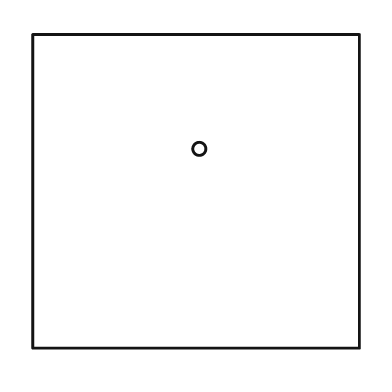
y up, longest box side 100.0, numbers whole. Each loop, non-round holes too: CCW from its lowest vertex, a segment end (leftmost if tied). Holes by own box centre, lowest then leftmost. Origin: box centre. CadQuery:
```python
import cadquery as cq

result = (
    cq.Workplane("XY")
    .moveTo(-50.0, -48.0)
    .lineTo(50.0, -48.0)
    .lineTo(50.0, 48.0)
    .lineTo(-50.0, 48.0)
    .close()
    .moveTo(1.0, 13.0)
    .circle(2.0)
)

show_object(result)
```